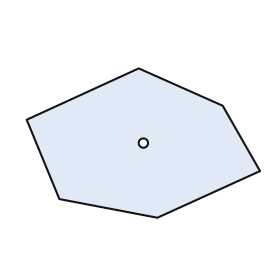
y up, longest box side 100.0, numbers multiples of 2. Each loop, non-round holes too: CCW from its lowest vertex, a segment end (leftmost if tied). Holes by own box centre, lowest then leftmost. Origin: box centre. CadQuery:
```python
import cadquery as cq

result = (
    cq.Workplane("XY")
    .moveTo(6.0, -32.0)
    .lineTo(50.0, -12.0)
    .lineTo(34.0, 16.0)
    .lineTo(-2.0, 32.0)
    .lineTo(-50.0, 10.0)
    .lineTo(-36.0, -24.0)
    .close()
    .moveTo(0.0, 0.0)
    .circle(2.0)
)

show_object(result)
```